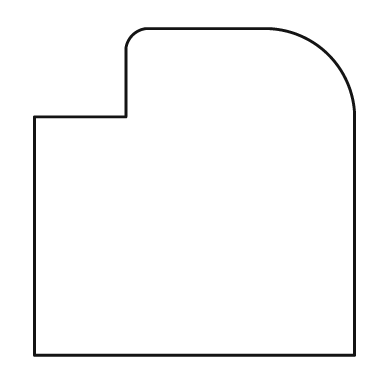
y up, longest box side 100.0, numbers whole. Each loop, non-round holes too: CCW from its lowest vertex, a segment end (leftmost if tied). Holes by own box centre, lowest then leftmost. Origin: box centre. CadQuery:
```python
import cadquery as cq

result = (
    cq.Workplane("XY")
    .moveTo(-49.0, -50.0)
    .lineTo(49.0, -50.0)
    .lineTo(49.0, 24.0)
    .threePointArc((41.0, 42.0), (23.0, 50.0))
    .lineTo(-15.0, 50.0)
    .threePointArc((-19.0, 48.0), (-21.0, 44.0))
    .lineTo(-21.0, 23.0)
    .lineTo(-49.0, 23.0)
    .close()
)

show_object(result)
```